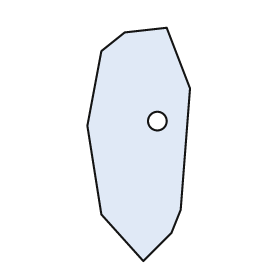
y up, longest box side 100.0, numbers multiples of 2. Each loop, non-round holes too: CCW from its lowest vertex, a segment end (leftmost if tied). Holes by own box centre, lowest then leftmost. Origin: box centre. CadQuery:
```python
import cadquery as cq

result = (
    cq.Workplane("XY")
    .moveTo(2.0, -50.0)
    .lineTo(14.0, -38.0)
    .lineTo(18.0, -28.0)
    .lineTo(22.0, 24.0)
    .lineTo(12.0, 50.0)
    .lineTo(-6.0, 48.0)
    .lineTo(-16.0, 40.0)
    .lineTo(-22.0, 8.0)
    .lineTo(-16.0, -30.0)
    .close()
    .moveTo(8.0, 10.0)
    .circle(4.0)
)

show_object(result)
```